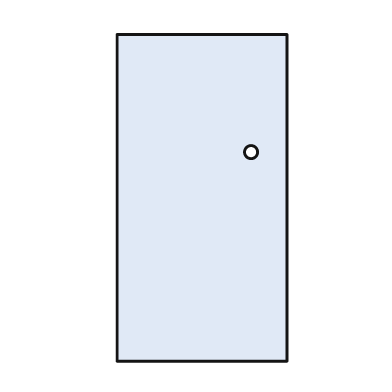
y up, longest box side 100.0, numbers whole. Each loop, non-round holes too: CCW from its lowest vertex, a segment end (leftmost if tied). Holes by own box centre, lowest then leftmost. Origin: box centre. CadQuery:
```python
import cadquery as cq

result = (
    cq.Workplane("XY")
    .moveTo(-26.0, -50.0)
    .lineTo(26.0, -50.0)
    .lineTo(26.0, 50.0)
    .lineTo(-26.0, 50.0)
    .close()
    .moveTo(15.0, 14.0)
    .circle(2.0)
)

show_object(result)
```